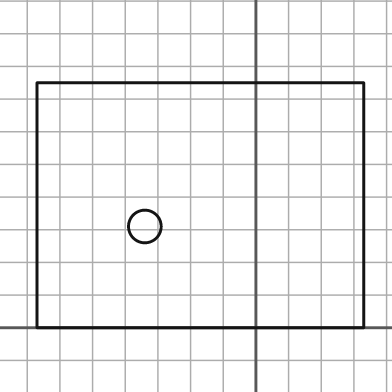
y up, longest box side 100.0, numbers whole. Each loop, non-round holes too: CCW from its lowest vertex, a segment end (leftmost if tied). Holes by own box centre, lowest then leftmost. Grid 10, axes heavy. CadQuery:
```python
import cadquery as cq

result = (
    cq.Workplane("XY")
    .moveTo(-67.0, 0.0)
    .lineTo(33.0, 0.0)
    .lineTo(33.0, 75.0)
    .lineTo(-67.0, 75.0)
    .close()
    .moveTo(-34.0, 31.0)
    .circle(5.0)
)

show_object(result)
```